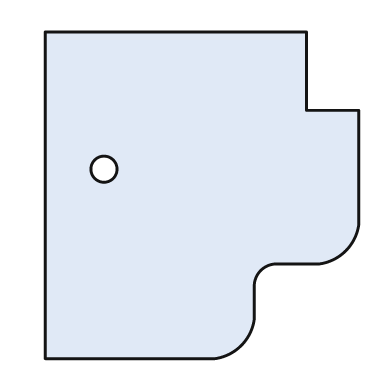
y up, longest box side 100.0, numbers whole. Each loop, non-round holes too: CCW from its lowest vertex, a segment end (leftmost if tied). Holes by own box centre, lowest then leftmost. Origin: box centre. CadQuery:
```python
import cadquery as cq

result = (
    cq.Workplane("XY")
    .moveTo(-48.0, -50.0)
    .lineTo(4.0, -50.0)
    .threePointArc((12.0, -46.0), (16.0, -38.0))
    .lineTo(16.0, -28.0)
    .threePointArc((18.0, -23.0), (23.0, -21.0))
    .lineTo(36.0, -21.0)
    .threePointArc((44.0, -17.0), (48.0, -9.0))
    .lineTo(48.0, 26.0)
    .lineTo(32.0, 26.0)
    .lineTo(32.0, 50.0)
    .lineTo(-48.0, 50.0)
    .close()
    .moveTo(-30.0, 8.0)
    .circle(4.0)
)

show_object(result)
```